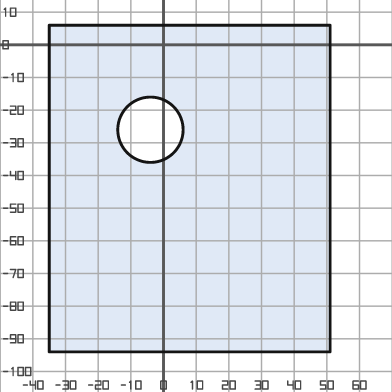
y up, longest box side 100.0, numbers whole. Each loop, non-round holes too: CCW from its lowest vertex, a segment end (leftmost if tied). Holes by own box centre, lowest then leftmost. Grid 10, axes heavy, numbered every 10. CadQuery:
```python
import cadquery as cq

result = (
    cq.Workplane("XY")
    .moveTo(-35.0, -94.0)
    .lineTo(51.0, -94.0)
    .lineTo(51.0, 6.0)
    .lineTo(-35.0, 6.0)
    .close()
    .moveTo(-4.0, -26.0)
    .circle(10.0)
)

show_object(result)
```